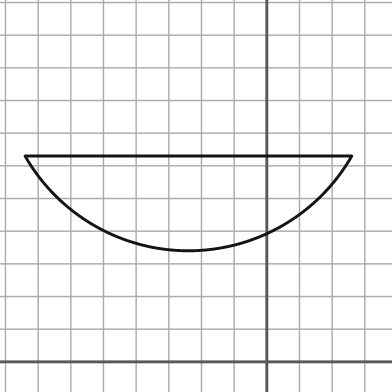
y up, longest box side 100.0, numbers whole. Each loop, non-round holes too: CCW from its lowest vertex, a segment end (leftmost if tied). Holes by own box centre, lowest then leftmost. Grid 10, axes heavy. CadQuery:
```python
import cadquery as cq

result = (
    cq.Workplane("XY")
    .moveTo(-74.0, 63.0)
    .threePointArc((-24.0, 34.0), (26.0, 63.0))
    .close()
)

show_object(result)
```